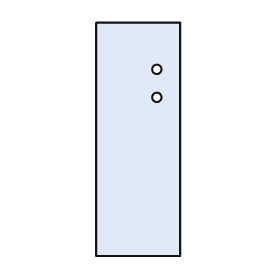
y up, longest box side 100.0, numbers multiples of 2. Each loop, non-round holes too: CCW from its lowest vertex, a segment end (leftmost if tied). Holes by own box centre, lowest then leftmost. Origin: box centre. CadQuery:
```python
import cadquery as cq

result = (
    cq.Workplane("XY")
    .moveTo(-18.0, -50.0)
    .lineTo(18.0, -50.0)
    .lineTo(18.0, 50.0)
    .lineTo(-18.0, 50.0)
    .close()
    .moveTo(8.0, 18.0)
    .circle(2.0)
    .moveTo(8.0, 30.0)
    .circle(2.0)
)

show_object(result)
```